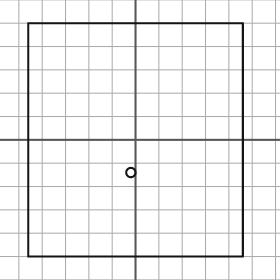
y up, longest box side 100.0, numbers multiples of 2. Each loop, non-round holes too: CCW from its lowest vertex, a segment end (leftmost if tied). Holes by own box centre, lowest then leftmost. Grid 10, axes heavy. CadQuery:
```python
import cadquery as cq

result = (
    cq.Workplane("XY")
    .moveTo(-46.0, -50.0)
    .lineTo(46.0, -50.0)
    .lineTo(46.0, 50.0)
    .lineTo(-46.0, 50.0)
    .close()
    .moveTo(-2.0, -14.0)
    .circle(2.0)
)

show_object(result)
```